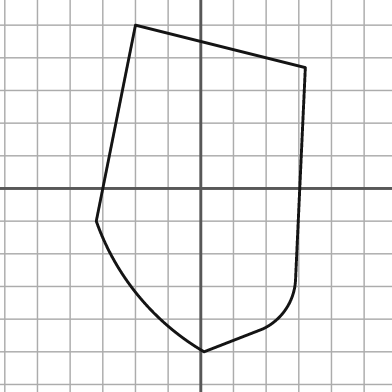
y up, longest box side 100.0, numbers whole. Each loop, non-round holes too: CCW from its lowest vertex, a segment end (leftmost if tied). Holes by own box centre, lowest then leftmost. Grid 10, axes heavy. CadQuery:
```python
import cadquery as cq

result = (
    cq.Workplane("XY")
    .moveTo(1.0, -50.0)
    .lineTo(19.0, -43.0)
    .threePointArc((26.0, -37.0), (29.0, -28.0))
    .lineTo(32.0, 37.0)
    .lineTo(-20.0, 50.0)
    .lineTo(-32.0, -10.0)
    .threePointArc((-19.0, -33.0), (1.0, -50.0))
    .close()
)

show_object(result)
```